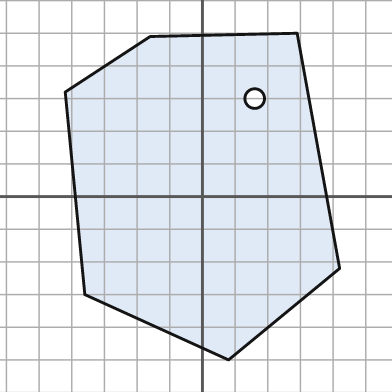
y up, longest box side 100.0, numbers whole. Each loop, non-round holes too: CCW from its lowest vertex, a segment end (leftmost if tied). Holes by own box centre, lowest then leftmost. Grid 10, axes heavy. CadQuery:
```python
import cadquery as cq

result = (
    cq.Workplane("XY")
    .moveTo(8.0, -50.0)
    .lineTo(42.0, -22.0)
    .lineTo(29.0, 50.0)
    .lineTo(-16.0, 49.0)
    .lineTo(-42.0, 32.0)
    .lineTo(-36.0, -30.0)
    .close()
    .moveTo(16.0, 30.0)
    .circle(3.0)
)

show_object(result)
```